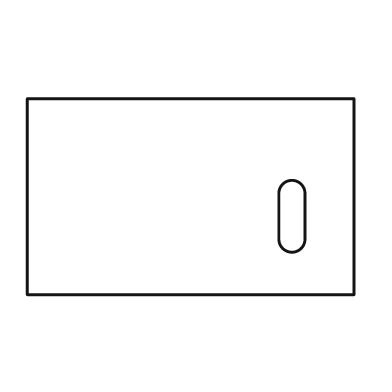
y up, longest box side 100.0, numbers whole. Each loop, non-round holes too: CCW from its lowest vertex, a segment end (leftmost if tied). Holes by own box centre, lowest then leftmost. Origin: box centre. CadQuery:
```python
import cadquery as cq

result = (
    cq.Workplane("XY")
    .moveTo(-50.0, -30.0)
    .lineTo(50.0, -30.0)
    .lineTo(50.0, 30.0)
    .lineTo(-50.0, 30.0)
    .close()
    .moveTo(27.0, -13.0)
    .threePointArc((31.0, -17.0), (35.0, -13.0))
    .lineTo(35.0, 1.0)
    .threePointArc((31.0, 5.0), (27.0, 1.0))
    .close()
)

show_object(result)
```